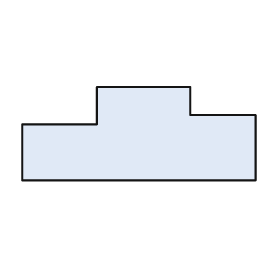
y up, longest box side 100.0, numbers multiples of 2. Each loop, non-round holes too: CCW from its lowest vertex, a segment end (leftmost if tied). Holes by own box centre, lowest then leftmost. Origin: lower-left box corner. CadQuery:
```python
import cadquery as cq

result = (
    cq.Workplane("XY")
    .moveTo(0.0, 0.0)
    .lineTo(100.0, 0.0)
    .lineTo(100.0, 28.0)
    .lineTo(72.0, 28.0)
    .lineTo(72.0, 40.0)
    .lineTo(32.0, 40.0)
    .lineTo(32.0, 24.0)
    .lineTo(0.0, 24.0)
    .close()
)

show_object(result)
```